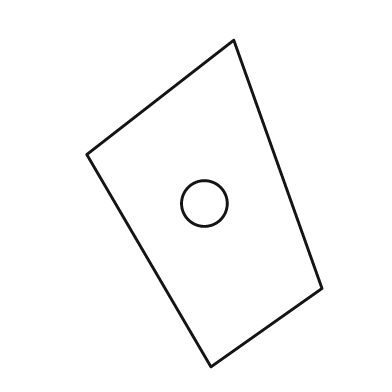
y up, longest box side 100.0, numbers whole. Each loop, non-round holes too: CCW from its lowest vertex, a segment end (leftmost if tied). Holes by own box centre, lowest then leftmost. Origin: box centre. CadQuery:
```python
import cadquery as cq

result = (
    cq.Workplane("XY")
    .moveTo(2.0, -50.0)
    .lineTo(36.0, -26.0)
    .lineTo(9.0, 50.0)
    .lineTo(-36.0, 15.0)
    .close()
    .moveTo(0.0, 0.0)
    .circle(7.0)
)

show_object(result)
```